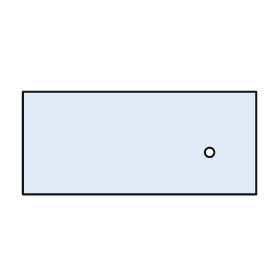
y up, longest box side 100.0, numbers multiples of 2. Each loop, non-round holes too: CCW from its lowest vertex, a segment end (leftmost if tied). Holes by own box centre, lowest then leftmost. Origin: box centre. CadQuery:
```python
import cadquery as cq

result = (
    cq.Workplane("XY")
    .moveTo(-50.0, -22.0)
    .lineTo(50.0, -22.0)
    .lineTo(50.0, 22.0)
    .lineTo(-50.0, 22.0)
    .close()
    .moveTo(30.0, -4.0)
    .circle(2.0)
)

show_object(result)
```